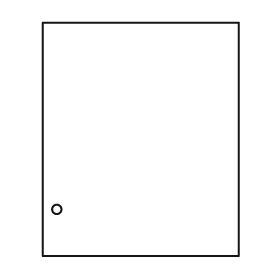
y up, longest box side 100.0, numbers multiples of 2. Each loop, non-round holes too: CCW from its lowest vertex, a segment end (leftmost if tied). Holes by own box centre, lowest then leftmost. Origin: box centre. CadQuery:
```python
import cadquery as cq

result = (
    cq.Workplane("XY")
    .moveTo(-42.0, -50.0)
    .lineTo(42.0, -50.0)
    .lineTo(42.0, 50.0)
    .lineTo(-42.0, 50.0)
    .close()
    .moveTo(-36.0, -30.0)
    .circle(2.0)
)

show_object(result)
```